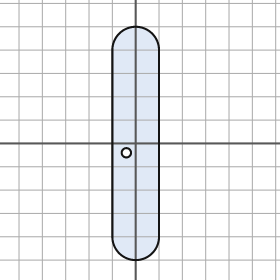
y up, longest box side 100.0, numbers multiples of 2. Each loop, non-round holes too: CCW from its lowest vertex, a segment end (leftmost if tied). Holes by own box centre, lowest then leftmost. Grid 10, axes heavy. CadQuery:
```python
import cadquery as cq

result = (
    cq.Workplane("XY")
    .moveTo(-10.0, -40.0)
    .threePointArc((0.0, -50.0), (10.0, -40.0))
    .lineTo(10.0, 40.0)
    .threePointArc((0.0, 50.0), (-10.0, 40.0))
    .close()
    .moveTo(-4.0, -4.0)
    .circle(2.0)
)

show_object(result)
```